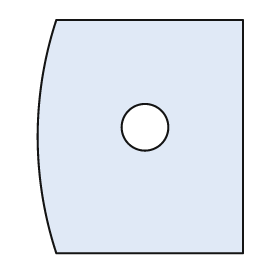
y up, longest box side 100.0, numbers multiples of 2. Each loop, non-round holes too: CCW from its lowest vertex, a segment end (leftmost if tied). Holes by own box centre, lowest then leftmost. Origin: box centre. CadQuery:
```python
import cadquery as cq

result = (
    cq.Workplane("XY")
    .moveTo(-36.0, -50.0)
    .lineTo(44.0, -50.0)
    .lineTo(44.0, 50.0)
    .lineTo(-36.0, 50.0)
    .threePointArc((-44.0, 0.0), (-36.0, -50.0))
    .close()
    .moveTo(2.0, 4.0)
    .circle(10.0)
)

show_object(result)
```